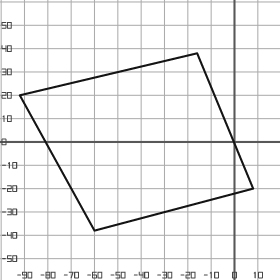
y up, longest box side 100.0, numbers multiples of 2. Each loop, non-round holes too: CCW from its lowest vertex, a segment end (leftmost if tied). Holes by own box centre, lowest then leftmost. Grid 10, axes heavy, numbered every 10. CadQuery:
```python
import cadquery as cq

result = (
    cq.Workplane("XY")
    .moveTo(-60.0, -38.0)
    .lineTo(8.0, -20.0)
    .lineTo(-16.0, 38.0)
    .lineTo(-92.0, 20.0)
    .close()
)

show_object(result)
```